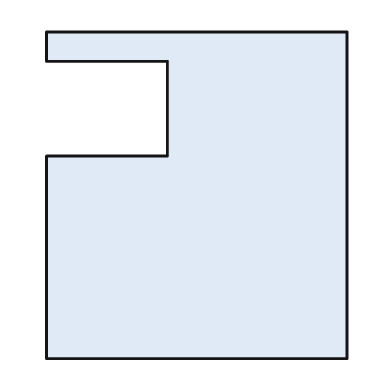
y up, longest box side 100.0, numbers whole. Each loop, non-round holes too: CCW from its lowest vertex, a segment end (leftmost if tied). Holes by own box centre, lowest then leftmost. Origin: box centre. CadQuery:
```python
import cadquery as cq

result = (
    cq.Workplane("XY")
    .moveTo(-46.0, -50.0)
    .lineTo(46.0, -50.0)
    .lineTo(46.0, 50.0)
    .lineTo(-46.0, 50.0)
    .lineTo(-46.0, 41.0)
    .lineTo(-9.0, 41.0)
    .lineTo(-9.0, 12.0)
    .lineTo(-46.0, 12.0)
    .close()
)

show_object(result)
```